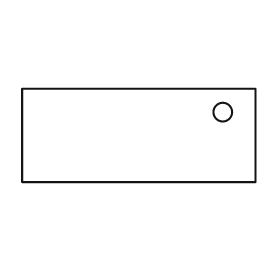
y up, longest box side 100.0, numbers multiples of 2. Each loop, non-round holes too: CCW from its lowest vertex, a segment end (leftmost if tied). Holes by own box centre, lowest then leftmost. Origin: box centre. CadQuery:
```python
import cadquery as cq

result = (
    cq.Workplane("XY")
    .moveTo(-50.0, -20.0)
    .lineTo(50.0, -20.0)
    .lineTo(50.0, 20.0)
    .lineTo(-50.0, 20.0)
    .close()
    .moveTo(36.0, 10.0)
    .circle(4.0)
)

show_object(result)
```